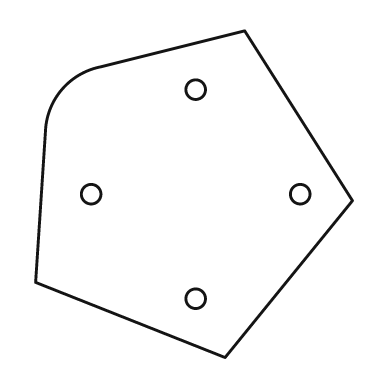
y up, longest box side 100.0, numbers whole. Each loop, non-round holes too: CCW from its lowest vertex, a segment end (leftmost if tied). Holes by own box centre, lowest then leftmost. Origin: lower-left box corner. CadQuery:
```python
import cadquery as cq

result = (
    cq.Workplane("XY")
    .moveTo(58.0, 0.0)
    .lineTo(97.0, 48.0)
    .lineTo(64.0, 100.0)
    .lineTo(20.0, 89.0)
    .threePointArc((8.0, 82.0), (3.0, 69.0))
    .lineTo(0.0, 23.0)
    .close()
    .moveTo(49.0, 18.0)
    .circle(3.0)
    .moveTo(17.0, 50.0)
    .circle(3.0)
    .moveTo(81.0, 50.0)
    .circle(3.0)
    .moveTo(49.0, 82.0)
    .circle(3.0)
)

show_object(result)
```